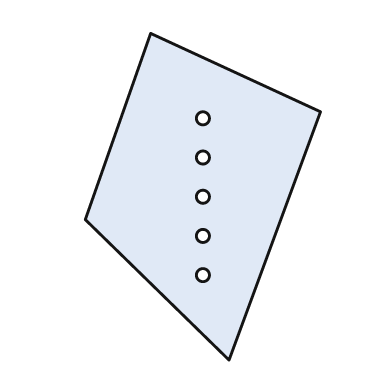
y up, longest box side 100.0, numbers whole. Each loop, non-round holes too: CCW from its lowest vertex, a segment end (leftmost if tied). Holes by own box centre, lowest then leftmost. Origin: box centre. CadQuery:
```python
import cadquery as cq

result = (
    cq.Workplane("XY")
    .moveTo(8.0, -50.0)
    .lineTo(36.0, 26.0)
    .lineTo(-16.0, 50.0)
    .lineTo(-36.0, -7.0)
    .close()
    .moveTo(0.0, -24.0)
    .circle(2.0)
    .moveTo(0.0, -12.0)
    .circle(2.0)
    .moveTo(0.0, 0.0)
    .circle(2.0)
    .moveTo(0.0, 12.0)
    .circle(2.0)
    .moveTo(0.0, 24.0)
    .circle(2.0)
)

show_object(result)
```